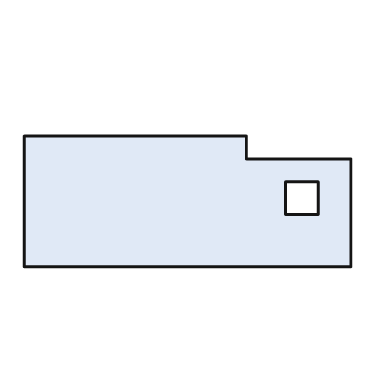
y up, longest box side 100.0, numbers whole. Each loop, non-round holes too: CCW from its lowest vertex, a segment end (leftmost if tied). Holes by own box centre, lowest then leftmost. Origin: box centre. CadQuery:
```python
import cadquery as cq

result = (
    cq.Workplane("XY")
    .moveTo(-50.0, -20.0)
    .lineTo(50.0, -20.0)
    .lineTo(50.0, 13.0)
    .lineTo(18.0, 13.0)
    .lineTo(18.0, 20.0)
    .lineTo(-50.0, 20.0)
    .close()
    .moveTo(30.0, -4.0)
    .lineTo(40.0, -4.0)
    .lineTo(40.0, 6.0)
    .lineTo(30.0, 6.0)
    .close()
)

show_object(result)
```